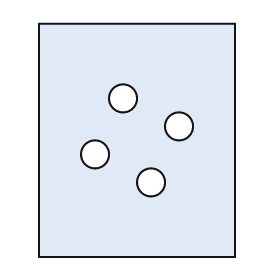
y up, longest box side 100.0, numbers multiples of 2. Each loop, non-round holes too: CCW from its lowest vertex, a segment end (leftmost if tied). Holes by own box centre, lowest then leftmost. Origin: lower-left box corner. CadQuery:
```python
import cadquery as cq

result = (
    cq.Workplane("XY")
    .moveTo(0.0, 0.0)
    .lineTo(84.0, 0.0)
    .lineTo(84.0, 100.0)
    .lineTo(0.0, 100.0)
    .close()
    .moveTo(48.0, 32.0)
    .circle(6.0)
    .moveTo(24.0, 44.0)
    .circle(6.0)
    .moveTo(60.0, 56.0)
    .circle(6.0)
    .moveTo(36.0, 68.0)
    .circle(6.0)
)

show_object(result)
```